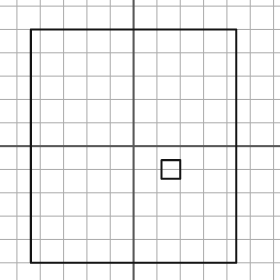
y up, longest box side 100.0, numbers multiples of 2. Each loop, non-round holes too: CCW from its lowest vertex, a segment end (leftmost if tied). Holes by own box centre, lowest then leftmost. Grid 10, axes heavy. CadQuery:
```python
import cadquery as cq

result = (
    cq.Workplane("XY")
    .moveTo(-44.0, -50.0)
    .lineTo(44.0, -50.0)
    .lineTo(44.0, 50.0)
    .lineTo(-44.0, 50.0)
    .close()
    .moveTo(12.0, -14.0)
    .lineTo(20.0, -14.0)
    .lineTo(20.0, -6.0)
    .lineTo(12.0, -6.0)
    .close()
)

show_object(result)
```